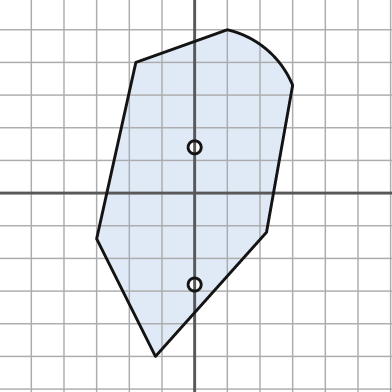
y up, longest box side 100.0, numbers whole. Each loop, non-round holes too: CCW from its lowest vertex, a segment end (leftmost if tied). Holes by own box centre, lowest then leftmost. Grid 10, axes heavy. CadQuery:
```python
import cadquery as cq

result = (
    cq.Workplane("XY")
    .moveTo(-12.0, -50.0)
    .lineTo(22.0, -12.0)
    .lineTo(30.0, 33.0)
    .threePointArc((22.0, 44.0), (10.0, 50.0))
    .lineTo(-18.0, 40.0)
    .lineTo(-30.0, -14.0)
    .close()
    .moveTo(0.0, -28.0)
    .circle(2.0)
    .moveTo(0.0, 14.0)
    .circle(2.0)
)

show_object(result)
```